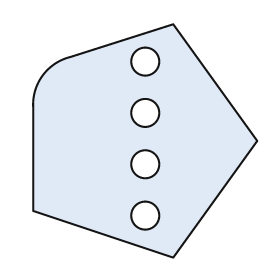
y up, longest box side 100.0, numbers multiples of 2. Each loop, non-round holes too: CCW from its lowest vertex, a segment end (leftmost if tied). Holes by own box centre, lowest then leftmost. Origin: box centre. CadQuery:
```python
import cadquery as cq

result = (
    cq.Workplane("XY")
    .moveTo(12.0, -50.0)
    .lineTo(48.0, 0.0)
    .lineTo(12.0, 50.0)
    .lineTo(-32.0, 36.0)
    .threePointArc((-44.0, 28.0), (-48.0, 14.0))
    .lineTo(-48.0, -30.0)
    .close()
    .moveTo(0.0, -32.0)
    .circle(6.0)
    .moveTo(0.0, -10.0)
    .circle(6.0)
    .moveTo(0.0, 12.0)
    .circle(6.0)
    .moveTo(0.0, 34.0)
    .circle(6.0)
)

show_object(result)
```